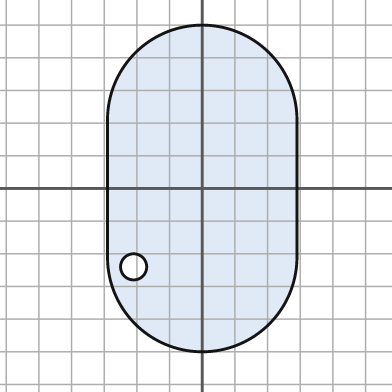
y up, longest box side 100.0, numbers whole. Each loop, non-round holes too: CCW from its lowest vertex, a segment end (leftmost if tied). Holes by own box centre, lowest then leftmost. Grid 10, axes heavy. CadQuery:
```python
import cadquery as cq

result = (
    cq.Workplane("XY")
    .moveTo(-29.0, -21.0)
    .threePointArc((0.0, -50.0), (29.0, -21.0))
    .lineTo(29.0, 21.0)
    .threePointArc((0.0, 50.0), (-29.0, 21.0))
    .close()
    .moveTo(-21.0, -24.0)
    .circle(4.0)
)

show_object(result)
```